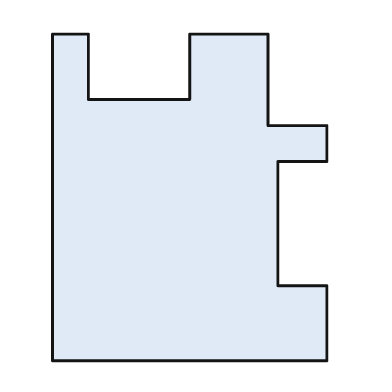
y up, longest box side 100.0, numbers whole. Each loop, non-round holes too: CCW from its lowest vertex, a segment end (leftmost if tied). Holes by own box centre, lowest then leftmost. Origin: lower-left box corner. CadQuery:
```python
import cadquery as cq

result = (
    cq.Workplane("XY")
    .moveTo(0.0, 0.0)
    .lineTo(84.0, 0.0)
    .lineTo(84.0, 23.0)
    .lineTo(69.0, 23.0)
    .lineTo(69.0, 61.0)
    .lineTo(84.0, 61.0)
    .lineTo(84.0, 72.0)
    .lineTo(66.0, 72.0)
    .lineTo(66.0, 100.0)
    .lineTo(42.0, 100.0)
    .lineTo(42.0, 80.0)
    .lineTo(11.0, 80.0)
    .lineTo(11.0, 100.0)
    .lineTo(0.0, 100.0)
    .close()
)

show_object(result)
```